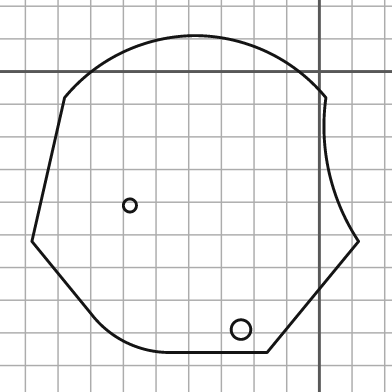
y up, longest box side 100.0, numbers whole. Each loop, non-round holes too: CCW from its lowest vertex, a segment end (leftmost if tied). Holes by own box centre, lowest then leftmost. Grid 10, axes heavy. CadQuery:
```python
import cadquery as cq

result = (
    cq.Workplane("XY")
    .moveTo(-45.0, -86.0)
    .lineTo(-16.0, -86.0)
    .lineTo(12.0, -52.0)
    .threePointArc((3.0, -31.0), (2.0, -8.0))
    .threePointArc((-16.0, 6.0), (-38.0, 11.0))
    .threePointArc((-60.0, 6.0), (-78.0, -8.0))
    .lineTo(-88.0, -52.0)
    .lineTo(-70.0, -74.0)
    .threePointArc((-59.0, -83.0), (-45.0, -86.0))
    .close()
    .moveTo(-24.0, -79.0)
    .circle(3.0)
    .moveTo(-58.0, -41.0)
    .circle(2.0)
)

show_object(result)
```